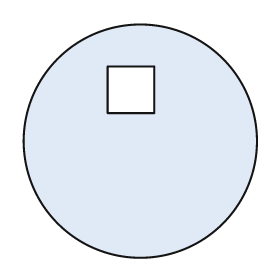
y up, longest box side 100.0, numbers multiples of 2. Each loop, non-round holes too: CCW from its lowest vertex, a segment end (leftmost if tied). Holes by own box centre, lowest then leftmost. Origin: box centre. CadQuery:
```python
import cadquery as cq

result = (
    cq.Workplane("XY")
    .moveTo(0.0, 0.0)
    .circle(50.0)
    .moveTo(-14.0, 12.0)
    .lineTo(6.0, 12.0)
    .lineTo(6.0, 32.0)
    .lineTo(-14.0, 32.0)
    .close()
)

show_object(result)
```